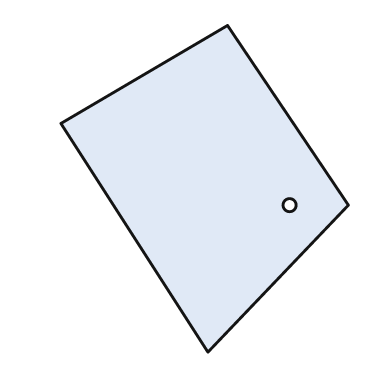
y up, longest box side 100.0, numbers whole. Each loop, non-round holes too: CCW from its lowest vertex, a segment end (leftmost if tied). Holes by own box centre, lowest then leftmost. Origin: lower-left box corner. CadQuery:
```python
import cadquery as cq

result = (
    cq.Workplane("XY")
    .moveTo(45.0, 0.0)
    .lineTo(88.0, 45.0)
    .lineTo(51.0, 100.0)
    .lineTo(0.0, 70.0)
    .close()
    .moveTo(70.0, 45.0)
    .circle(2.0)
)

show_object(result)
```